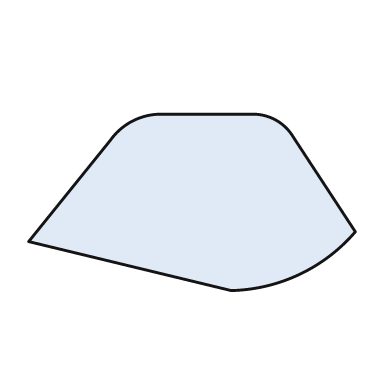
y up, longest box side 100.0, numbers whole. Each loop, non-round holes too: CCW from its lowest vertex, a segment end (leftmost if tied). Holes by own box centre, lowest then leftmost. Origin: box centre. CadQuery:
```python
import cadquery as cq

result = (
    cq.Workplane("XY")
    .moveTo(12.0, -27.0)
    .threePointArc((33.0, -22.0), (50.0, -9.0))
    .lineTo(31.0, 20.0)
    .threePointArc((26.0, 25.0), (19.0, 27.0))
    .lineTo(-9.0, 27.0)
    .threePointArc((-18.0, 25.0), (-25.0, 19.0))
    .lineTo(-50.0, -12.0)
    .close()
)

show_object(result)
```